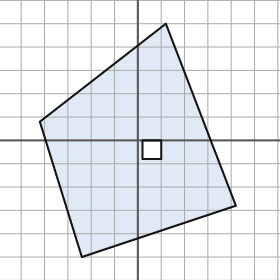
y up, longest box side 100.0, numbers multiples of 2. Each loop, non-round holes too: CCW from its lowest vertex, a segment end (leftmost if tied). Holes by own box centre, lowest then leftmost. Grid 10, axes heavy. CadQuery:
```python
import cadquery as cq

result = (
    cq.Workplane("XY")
    .moveTo(-24.0, -50.0)
    .lineTo(42.0, -28.0)
    .lineTo(12.0, 50.0)
    .lineTo(-42.0, 8.0)
    .close()
    .moveTo(2.0, -8.0)
    .lineTo(10.0, -8.0)
    .lineTo(10.0, 0.0)
    .lineTo(2.0, 0.0)
    .close()
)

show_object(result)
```